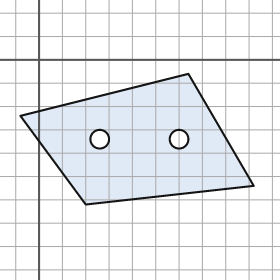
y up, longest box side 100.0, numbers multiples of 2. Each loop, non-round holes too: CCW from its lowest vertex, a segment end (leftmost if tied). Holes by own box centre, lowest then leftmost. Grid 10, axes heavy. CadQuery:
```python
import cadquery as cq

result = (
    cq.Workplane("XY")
    .moveTo(20.0, -62.0)
    .lineTo(92.0, -54.0)
    .lineTo(64.0, -6.0)
    .lineTo(-8.0, -24.0)
    .close()
    .moveTo(26.0, -34.0)
    .circle(4.0)
    .moveTo(60.0, -34.0)
    .circle(4.0)
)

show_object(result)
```